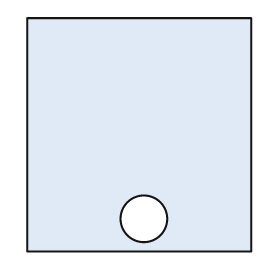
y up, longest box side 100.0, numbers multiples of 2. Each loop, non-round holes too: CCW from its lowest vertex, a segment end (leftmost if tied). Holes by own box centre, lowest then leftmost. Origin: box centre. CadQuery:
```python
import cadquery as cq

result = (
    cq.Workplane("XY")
    .moveTo(-48.0, -50.0)
    .lineTo(48.0, -50.0)
    .lineTo(48.0, 50.0)
    .lineTo(-48.0, 50.0)
    .close()
    .moveTo(2.0, -36.0)
    .circle(10.0)
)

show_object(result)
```